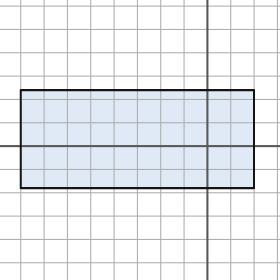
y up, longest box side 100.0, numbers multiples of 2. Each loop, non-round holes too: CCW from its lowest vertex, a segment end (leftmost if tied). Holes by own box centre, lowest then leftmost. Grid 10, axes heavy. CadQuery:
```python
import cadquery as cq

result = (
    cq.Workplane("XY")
    .moveTo(-80.0, -18.0)
    .lineTo(20.0, -18.0)
    .lineTo(20.0, 24.0)
    .lineTo(-80.0, 24.0)
    .close()
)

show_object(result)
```